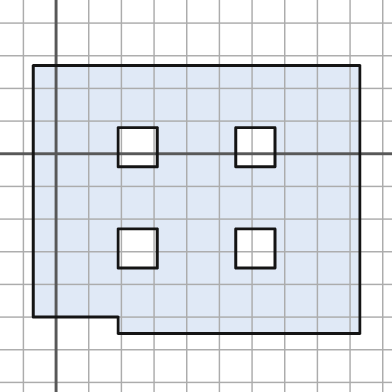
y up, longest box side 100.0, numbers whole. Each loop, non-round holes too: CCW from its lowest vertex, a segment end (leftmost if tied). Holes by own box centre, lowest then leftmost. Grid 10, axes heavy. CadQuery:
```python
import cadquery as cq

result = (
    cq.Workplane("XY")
    .moveTo(19.0, -55.0)
    .lineTo(93.0, -55.0)
    .lineTo(93.0, 27.0)
    .lineTo(-7.0, 27.0)
    .lineTo(-7.0, -50.0)
    .lineTo(19.0, -50.0)
    .close()
    .moveTo(19.0, -35.0)
    .lineTo(31.0, -35.0)
    .lineTo(31.0, -23.0)
    .lineTo(19.0, -23.0)
    .close()
    .moveTo(55.0, -35.0)
    .lineTo(67.0, -35.0)
    .lineTo(67.0, -23.0)
    .lineTo(55.0, -23.0)
    .close()
    .moveTo(19.0, -4.0)
    .lineTo(31.0, -4.0)
    .lineTo(31.0, 8.0)
    .lineTo(19.0, 8.0)
    .close()
    .moveTo(55.0, -4.0)
    .lineTo(67.0, -4.0)
    .lineTo(67.0, 8.0)
    .lineTo(55.0, 8.0)
    .close()
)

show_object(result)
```